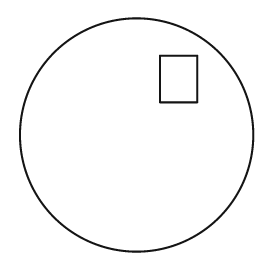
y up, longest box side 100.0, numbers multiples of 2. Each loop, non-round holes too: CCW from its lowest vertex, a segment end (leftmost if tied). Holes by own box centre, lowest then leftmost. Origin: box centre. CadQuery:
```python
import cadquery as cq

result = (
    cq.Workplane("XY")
    .moveTo(0.0, 0.0)
    .circle(50.0)
    .moveTo(10.0, 14.0)
    .lineTo(26.0, 14.0)
    .lineTo(26.0, 34.0)
    .lineTo(10.0, 34.0)
    .close()
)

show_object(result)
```